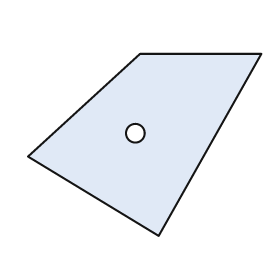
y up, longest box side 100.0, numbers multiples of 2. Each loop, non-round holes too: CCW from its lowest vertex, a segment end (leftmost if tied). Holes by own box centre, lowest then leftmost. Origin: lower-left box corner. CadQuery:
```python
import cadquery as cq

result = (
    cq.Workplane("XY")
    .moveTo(56.0, 0.0)
    .lineTo(100.0, 78.0)
    .lineTo(48.0, 78.0)
    .lineTo(0.0, 34.0)
    .close()
    .moveTo(46.0, 44.0)
    .circle(4.0)
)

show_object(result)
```